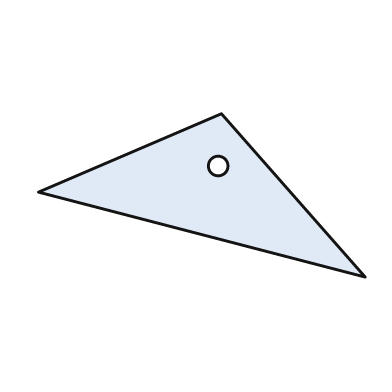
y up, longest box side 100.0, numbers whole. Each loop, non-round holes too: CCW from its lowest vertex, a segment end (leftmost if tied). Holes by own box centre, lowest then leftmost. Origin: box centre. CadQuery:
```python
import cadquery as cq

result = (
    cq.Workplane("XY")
    .moveTo(50.0, -25.0)
    .lineTo(6.0, 25.0)
    .lineTo(-50.0, 1.0)
    .close()
    .moveTo(5.0, 9.0)
    .circle(3.0)
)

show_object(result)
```